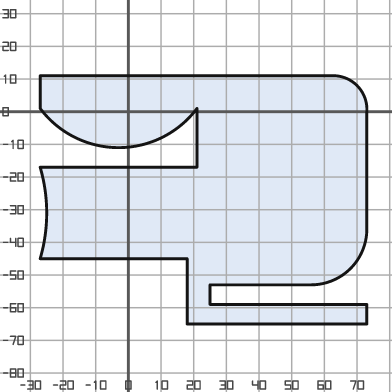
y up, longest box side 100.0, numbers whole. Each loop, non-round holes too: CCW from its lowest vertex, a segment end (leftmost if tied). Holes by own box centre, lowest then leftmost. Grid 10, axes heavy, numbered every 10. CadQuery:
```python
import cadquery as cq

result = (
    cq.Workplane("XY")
    .moveTo(18.0, -65.0)
    .lineTo(73.0, -65.0)
    .lineTo(73.0, -59.0)
    .lineTo(25.0, -59.0)
    .lineTo(25.0, -53.0)
    .lineTo(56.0, -53.0)
    .threePointArc((68.0, -48.0), (73.0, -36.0))
    .lineTo(73.0, 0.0)
    .threePointArc((70.0, 8.0), (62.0, 11.0))
    .lineTo(-27.0, 11.0)
    .lineTo(-27.0, 1.0)
    .threePointArc((-3.0, -11.0), (21.0, 1.0))
    .lineTo(21.0, -17.0)
    .lineTo(-27.0, -17.0)
    .threePointArc((-25.0, -31.0), (-27.0, -45.0))
    .lineTo(18.0, -45.0)
    .close()
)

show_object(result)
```